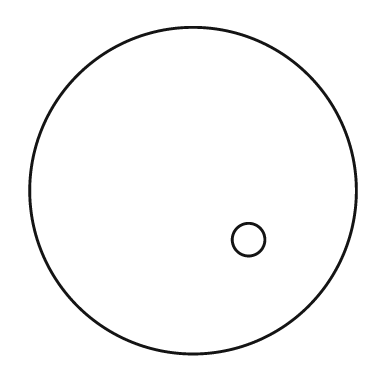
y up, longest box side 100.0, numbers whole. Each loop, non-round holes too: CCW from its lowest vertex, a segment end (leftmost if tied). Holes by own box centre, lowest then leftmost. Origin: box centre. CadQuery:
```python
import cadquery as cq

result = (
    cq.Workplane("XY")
    .moveTo(0.0, 0.0)
    .circle(50.0)
    .moveTo(17.0, -15.0)
    .circle(5.0)
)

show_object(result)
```